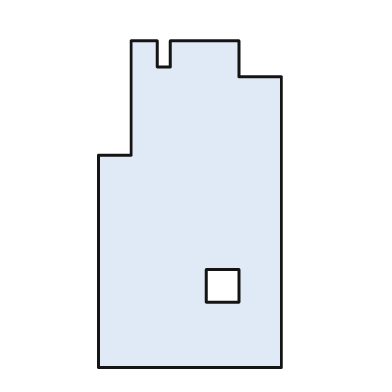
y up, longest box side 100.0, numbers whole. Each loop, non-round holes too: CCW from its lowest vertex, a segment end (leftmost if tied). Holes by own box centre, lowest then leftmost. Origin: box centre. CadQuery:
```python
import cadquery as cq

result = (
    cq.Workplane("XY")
    .moveTo(-28.0, -50.0)
    .lineTo(28.0, -50.0)
    .lineTo(28.0, 39.0)
    .lineTo(15.0, 39.0)
    .lineTo(15.0, 50.0)
    .lineTo(-6.0, 50.0)
    .lineTo(-6.0, 42.0)
    .lineTo(-10.0, 42.0)
    .lineTo(-10.0, 50.0)
    .lineTo(-18.0, 50.0)
    .lineTo(-18.0, 15.0)
    .lineTo(-28.0, 15.0)
    .close()
    .moveTo(5.0, -30.0)
    .lineTo(15.0, -30.0)
    .lineTo(15.0, -20.0)
    .lineTo(5.0, -20.0)
    .close()
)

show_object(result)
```